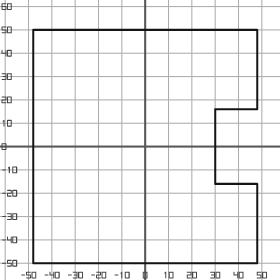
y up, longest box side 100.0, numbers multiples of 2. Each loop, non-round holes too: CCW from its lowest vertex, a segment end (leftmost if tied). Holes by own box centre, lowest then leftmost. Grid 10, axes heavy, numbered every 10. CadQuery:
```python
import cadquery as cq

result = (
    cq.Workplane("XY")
    .moveTo(-48.0, -50.0)
    .lineTo(48.0, -50.0)
    .lineTo(48.0, -16.0)
    .lineTo(30.0, -16.0)
    .lineTo(30.0, 16.0)
    .lineTo(48.0, 16.0)
    .lineTo(48.0, 50.0)
    .lineTo(-48.0, 50.0)
    .close()
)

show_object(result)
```